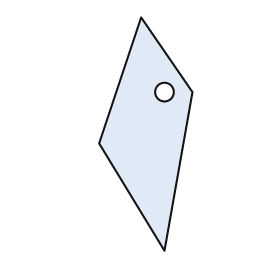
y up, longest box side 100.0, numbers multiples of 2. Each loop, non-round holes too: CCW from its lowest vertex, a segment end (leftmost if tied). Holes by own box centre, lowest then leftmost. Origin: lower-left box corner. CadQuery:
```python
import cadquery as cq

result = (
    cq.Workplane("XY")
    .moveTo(28.0, 0.0)
    .lineTo(40.0, 68.0)
    .lineTo(18.0, 100.0)
    .lineTo(0.0, 46.0)
    .close()
    .moveTo(28.0, 68.0)
    .circle(4.0)
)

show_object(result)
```